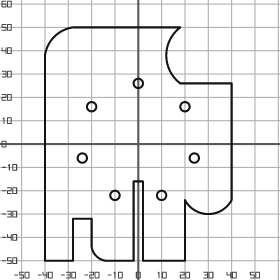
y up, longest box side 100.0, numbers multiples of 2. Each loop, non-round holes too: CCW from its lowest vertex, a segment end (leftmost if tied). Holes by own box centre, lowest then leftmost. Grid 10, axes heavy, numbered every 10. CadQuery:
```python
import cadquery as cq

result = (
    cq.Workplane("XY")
    .moveTo(-40.0, -50.0)
    .lineTo(-28.0, -50.0)
    .lineTo(-28.0, -32.0)
    .lineTo(-20.0, -32.0)
    .lineTo(-20.0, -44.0)
    .threePointArc((-18.0, -48.0), (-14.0, -50.0))
    .lineTo(-2.0, -50.0)
    .lineTo(-2.0, -16.0)
    .lineTo(2.0, -16.0)
    .lineTo(2.0, -50.0)
    .lineTo(20.0, -50.0)
    .lineTo(20.0, -24.0)
    .threePointArc((30.0, -30.0), (40.0, -24.0))
    .lineTo(40.0, 26.0)
    .lineTo(18.0, 26.0)
    .threePointArc((12.0, 38.0), (18.0, 50.0))
    .lineTo(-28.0, 50.0)
    .threePointArc((-36.0, 46.0), (-40.0, 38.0))
    .close()
    .moveTo(-10.0, -22.0)
    .circle(2.0)
    .moveTo(10.0, -22.0)
    .circle(2.0)
    .moveTo(-24.0, -6.0)
    .circle(2.0)
    .moveTo(24.0, -6.0)
    .circle(2.0)
    .moveTo(-20.0, 16.0)
    .circle(2.0)
    .moveTo(20.0, 16.0)
    .circle(2.0)
    .moveTo(0.0, 26.0)
    .circle(2.0)
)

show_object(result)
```